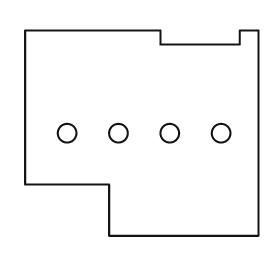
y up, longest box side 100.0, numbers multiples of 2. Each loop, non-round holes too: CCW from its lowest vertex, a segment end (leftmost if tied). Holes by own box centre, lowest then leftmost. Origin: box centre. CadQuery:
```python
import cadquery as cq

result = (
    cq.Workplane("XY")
    .moveTo(-14.0, -44.0)
    .lineTo(50.0, -44.0)
    .lineTo(50.0, 44.0)
    .lineTo(42.0, 44.0)
    .lineTo(42.0, 38.0)
    .lineTo(8.0, 38.0)
    .lineTo(8.0, 44.0)
    .lineTo(-50.0, 44.0)
    .lineTo(-50.0, -22.0)
    .lineTo(-14.0, -22.0)
    .close()
    .moveTo(-32.0, 0.0)
    .circle(4.0)
    .moveTo(-10.0, 0.0)
    .circle(4.0)
    .moveTo(12.0, 0.0)
    .circle(4.0)
    .moveTo(34.0, 0.0)
    .circle(4.0)
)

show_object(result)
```